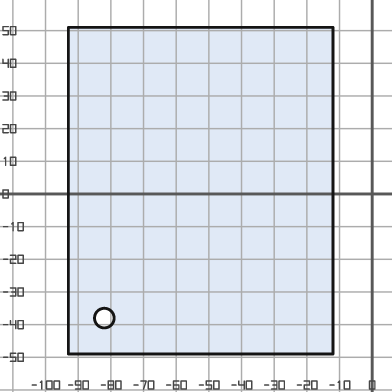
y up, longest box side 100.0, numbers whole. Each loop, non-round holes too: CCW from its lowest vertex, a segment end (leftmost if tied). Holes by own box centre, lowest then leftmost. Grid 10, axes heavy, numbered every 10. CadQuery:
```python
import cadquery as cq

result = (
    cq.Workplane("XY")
    .moveTo(-93.0, -49.0)
    .lineTo(-12.0, -49.0)
    .lineTo(-12.0, 51.0)
    .lineTo(-93.0, 51.0)
    .close()
    .moveTo(-82.0, -38.0)
    .circle(3.0)
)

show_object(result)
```